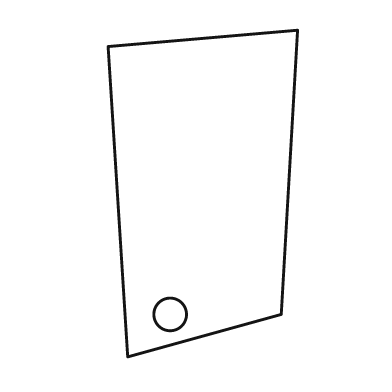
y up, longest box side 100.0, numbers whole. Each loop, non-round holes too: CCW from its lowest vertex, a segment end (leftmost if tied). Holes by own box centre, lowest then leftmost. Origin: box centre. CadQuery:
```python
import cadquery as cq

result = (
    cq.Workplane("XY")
    .moveTo(-23.0, -50.0)
    .lineTo(24.0, -37.0)
    .lineTo(29.0, 50.0)
    .lineTo(-29.0, 45.0)
    .close()
    .moveTo(-10.0, -37.0)
    .circle(5.0)
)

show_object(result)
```